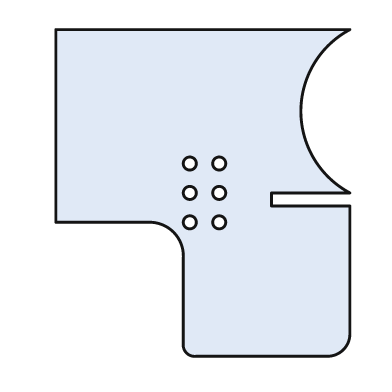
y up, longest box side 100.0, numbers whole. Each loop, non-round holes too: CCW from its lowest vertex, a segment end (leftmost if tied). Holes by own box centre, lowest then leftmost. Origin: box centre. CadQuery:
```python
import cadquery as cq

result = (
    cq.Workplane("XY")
    .moveTo(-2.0, -50.0)
    .lineTo(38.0, -50.0)
    .threePointArc((43.0, -48.0), (45.0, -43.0))
    .lineTo(45.0, -4.0)
    .lineTo(21.0, -4.0)
    .lineTo(21.0, 0.0)
    .lineTo(45.0, 0.0)
    .threePointArc((30.0, 25.0), (45.0, 50.0))
    .lineTo(-45.0, 50.0)
    .lineTo(-45.0, -9.0)
    .lineTo(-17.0, -9.0)
    .threePointArc((-9.0, -12.0), (-6.0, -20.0))
    .lineTo(-6.0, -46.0)
    .threePointArc((-5.0, -49.0), (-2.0, -50.0))
    .close()
    .moveTo(-4.0, -9.0)
    .circle(2.0)
    .moveTo(5.0, -9.0)
    .circle(2.0)
    .moveTo(-4.0, 0.0)
    .circle(2.0)
    .moveTo(5.0, 0.0)
    .circle(2.0)
    .moveTo(-4.0, 9.0)
    .circle(2.0)
    .moveTo(5.0, 9.0)
    .circle(2.0)
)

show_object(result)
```